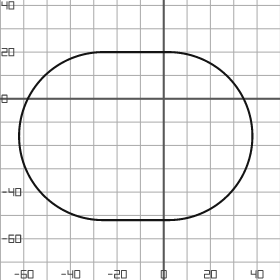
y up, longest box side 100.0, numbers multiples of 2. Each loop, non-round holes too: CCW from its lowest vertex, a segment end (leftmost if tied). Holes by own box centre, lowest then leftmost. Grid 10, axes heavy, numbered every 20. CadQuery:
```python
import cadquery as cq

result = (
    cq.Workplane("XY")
    .moveTo(-26.0, -52.0)
    .lineTo(2.0, -52.0)
    .threePointArc((38.0, -16.0), (2.0, 20.0))
    .lineTo(-26.0, 20.0)
    .threePointArc((-62.0, -16.0), (-26.0, -52.0))
    .close()
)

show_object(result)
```